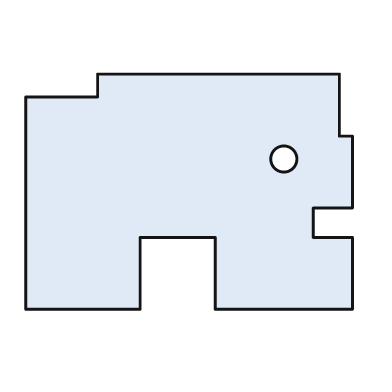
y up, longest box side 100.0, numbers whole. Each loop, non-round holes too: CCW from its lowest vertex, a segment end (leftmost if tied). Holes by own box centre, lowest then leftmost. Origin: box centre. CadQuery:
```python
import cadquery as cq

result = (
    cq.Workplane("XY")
    .moveTo(-50.0, -36.0)
    .lineTo(-15.0, -36.0)
    .lineTo(-15.0, -14.0)
    .lineTo(8.0, -14.0)
    .lineTo(8.0, -36.0)
    .lineTo(50.0, -36.0)
    .lineTo(50.0, -14.0)
    .lineTo(38.0, -14.0)
    .lineTo(38.0, -5.0)
    .lineTo(50.0, -5.0)
    .lineTo(50.0, 17.0)
    .lineTo(46.0, 17.0)
    .lineTo(46.0, 36.0)
    .lineTo(-28.0, 36.0)
    .lineTo(-28.0, 29.0)
    .lineTo(-50.0, 29.0)
    .close()
    .moveTo(29.0, 10.0)
    .circle(4.0)
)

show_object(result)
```